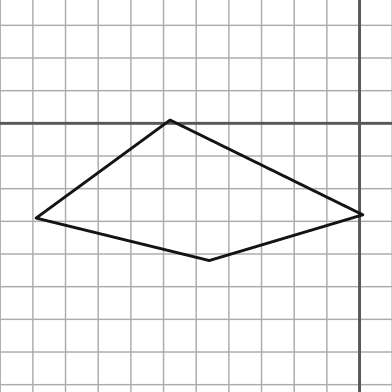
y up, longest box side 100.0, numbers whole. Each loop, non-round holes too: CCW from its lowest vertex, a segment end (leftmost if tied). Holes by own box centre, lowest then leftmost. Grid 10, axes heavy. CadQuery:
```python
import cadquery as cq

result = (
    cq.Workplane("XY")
    .moveTo(-46.0, -42.0)
    .lineTo(1.0, -28.0)
    .lineTo(-58.0, 1.0)
    .lineTo(-99.0, -29.0)
    .close()
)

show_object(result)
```